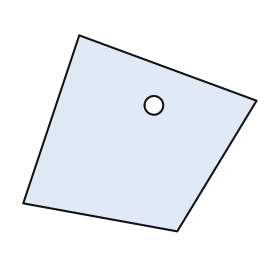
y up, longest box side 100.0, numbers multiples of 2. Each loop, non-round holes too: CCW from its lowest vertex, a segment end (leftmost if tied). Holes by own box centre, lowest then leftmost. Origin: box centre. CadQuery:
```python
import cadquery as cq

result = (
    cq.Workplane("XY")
    .moveTo(16.0, -42.0)
    .lineTo(50.0, 14.0)
    .lineTo(-26.0, 42.0)
    .lineTo(-50.0, -30.0)
    .close()
    .moveTo(6.0, 12.0)
    .circle(4.0)
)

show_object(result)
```